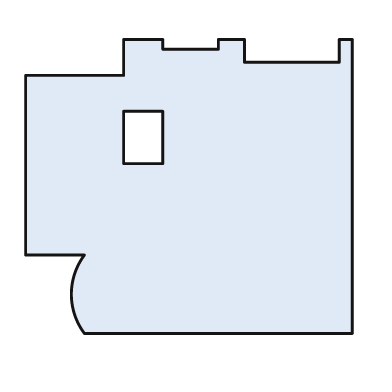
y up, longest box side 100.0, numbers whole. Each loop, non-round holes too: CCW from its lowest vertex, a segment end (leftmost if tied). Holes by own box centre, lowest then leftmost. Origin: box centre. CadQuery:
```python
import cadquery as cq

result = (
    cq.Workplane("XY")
    .moveTo(-32.0, -45.0)
    .lineTo(50.0, -45.0)
    .lineTo(50.0, 45.0)
    .lineTo(46.0, 45.0)
    .lineTo(46.0, 38.0)
    .lineTo(17.0, 38.0)
    .lineTo(17.0, 45.0)
    .lineTo(9.0, 45.0)
    .lineTo(9.0, 42.0)
    .lineTo(-8.0, 42.0)
    .lineTo(-8.0, 45.0)
    .lineTo(-20.0, 45.0)
    .lineTo(-20.0, 34.0)
    .lineTo(-50.0, 34.0)
    .lineTo(-50.0, -21.0)
    .lineTo(-32.0, -21.0)
    .threePointArc((-36.0, -33.0), (-32.0, -45.0))
    .close()
    .moveTo(-20.0, 7.0)
    .lineTo(-8.0, 7.0)
    .lineTo(-8.0, 23.0)
    .lineTo(-20.0, 23.0)
    .close()
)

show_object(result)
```